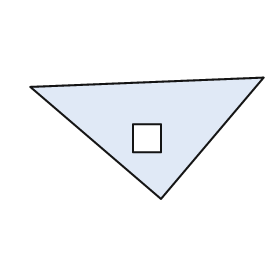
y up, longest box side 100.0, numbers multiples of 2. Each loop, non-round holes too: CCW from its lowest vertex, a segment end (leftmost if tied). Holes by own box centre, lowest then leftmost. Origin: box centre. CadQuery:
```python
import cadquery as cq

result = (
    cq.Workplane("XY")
    .moveTo(6.0, -26.0)
    .lineTo(50.0, 26.0)
    .lineTo(-50.0, 22.0)
    .close()
    .moveTo(-6.0, -6.0)
    .lineTo(6.0, -6.0)
    .lineTo(6.0, 6.0)
    .lineTo(-6.0, 6.0)
    .close()
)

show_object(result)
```